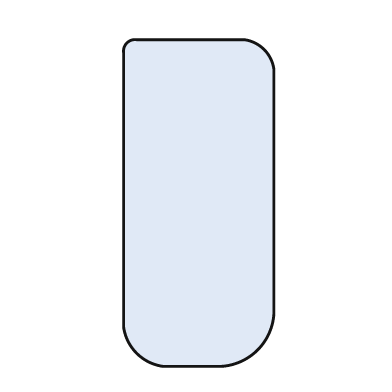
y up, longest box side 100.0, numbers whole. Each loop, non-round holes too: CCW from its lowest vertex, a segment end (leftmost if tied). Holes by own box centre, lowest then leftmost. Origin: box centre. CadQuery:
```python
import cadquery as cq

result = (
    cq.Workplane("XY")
    .moveTo(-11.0, -50.0)
    .lineTo(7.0, -50.0)
    .threePointArc((18.0, -45.0), (23.0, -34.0))
    .lineTo(23.0, 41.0)
    .threePointArc((20.0, 47.0), (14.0, 50.0))
    .lineTo(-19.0, 50.0)
    .threePointArc((-22.0, 49.0), (-23.0, 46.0))
    .lineTo(-23.0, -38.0)
    .threePointArc((-19.0, -46.0), (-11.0, -50.0))
    .close()
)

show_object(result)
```